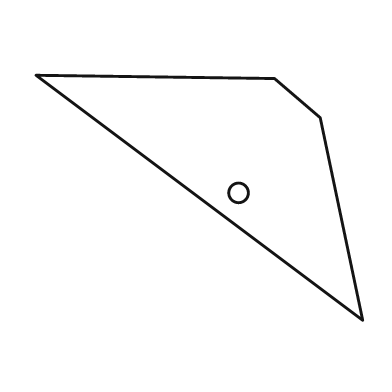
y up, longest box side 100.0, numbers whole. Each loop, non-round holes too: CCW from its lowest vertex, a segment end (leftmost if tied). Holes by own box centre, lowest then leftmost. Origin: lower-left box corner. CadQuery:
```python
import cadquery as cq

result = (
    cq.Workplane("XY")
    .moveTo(100.0, 0.0)
    .lineTo(87.0, 62.0)
    .lineTo(73.0, 74.0)
    .lineTo(0.0, 75.0)
    .close()
    .moveTo(62.0, 39.0)
    .circle(3.0)
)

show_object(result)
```